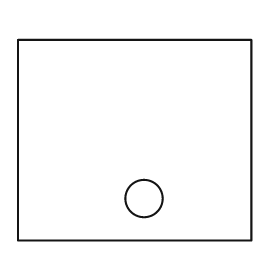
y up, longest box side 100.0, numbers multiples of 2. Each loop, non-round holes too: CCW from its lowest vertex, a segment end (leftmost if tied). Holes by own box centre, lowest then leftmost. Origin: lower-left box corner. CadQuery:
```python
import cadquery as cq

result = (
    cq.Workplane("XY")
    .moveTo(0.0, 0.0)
    .lineTo(100.0, 0.0)
    .lineTo(100.0, 86.0)
    .lineTo(0.0, 86.0)
    .close()
    .moveTo(54.0, 18.0)
    .circle(8.0)
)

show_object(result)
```